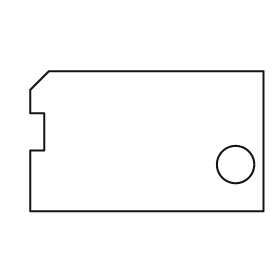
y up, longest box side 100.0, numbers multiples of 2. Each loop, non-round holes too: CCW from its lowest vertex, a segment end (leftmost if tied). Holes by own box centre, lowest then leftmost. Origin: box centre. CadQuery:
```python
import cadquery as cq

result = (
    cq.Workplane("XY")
    .moveTo(-50.0, -30.0)
    .lineTo(50.0, -30.0)
    .lineTo(50.0, 30.0)
    .lineTo(-42.0, 30.0)
    .lineTo(-50.0, 22.0)
    .lineTo(-50.0, 12.0)
    .lineTo(-44.0, 12.0)
    .lineTo(-44.0, -4.0)
    .lineTo(-50.0, -4.0)
    .close()
    .moveTo(38.0, -10.0)
    .circle(8.0)
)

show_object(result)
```